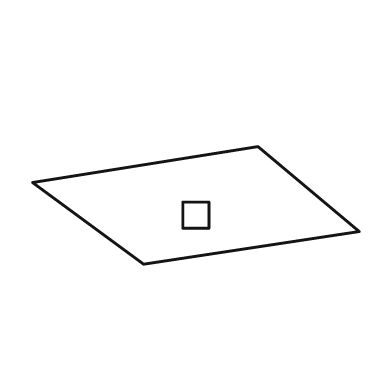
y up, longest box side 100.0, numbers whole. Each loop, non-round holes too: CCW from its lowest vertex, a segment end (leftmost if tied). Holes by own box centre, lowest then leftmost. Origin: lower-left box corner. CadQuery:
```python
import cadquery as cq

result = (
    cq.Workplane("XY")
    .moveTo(34.0, 0.0)
    .lineTo(100.0, 10.0)
    .lineTo(69.0, 36.0)
    .lineTo(0.0, 25.0)
    .close()
    .moveTo(46.0, 11.0)
    .lineTo(54.0, 11.0)
    .lineTo(54.0, 19.0)
    .lineTo(46.0, 19.0)
    .close()
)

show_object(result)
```